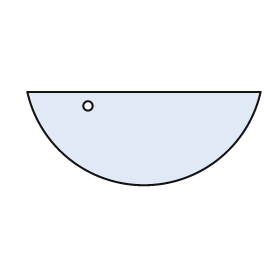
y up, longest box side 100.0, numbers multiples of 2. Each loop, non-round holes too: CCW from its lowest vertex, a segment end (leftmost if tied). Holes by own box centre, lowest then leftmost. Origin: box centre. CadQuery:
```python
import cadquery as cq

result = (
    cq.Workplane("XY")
    .moveTo(-50.0, 20.0)
    .threePointArc((0.0, -20.0), (50.0, 20.0))
    .close()
    .moveTo(-24.0, 14.0)
    .circle(2.0)
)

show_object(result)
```